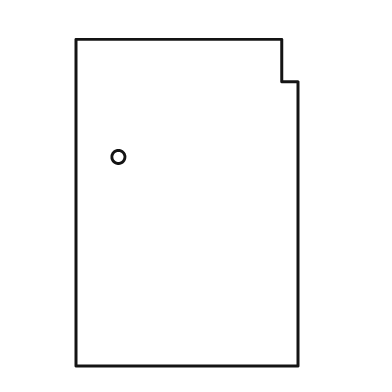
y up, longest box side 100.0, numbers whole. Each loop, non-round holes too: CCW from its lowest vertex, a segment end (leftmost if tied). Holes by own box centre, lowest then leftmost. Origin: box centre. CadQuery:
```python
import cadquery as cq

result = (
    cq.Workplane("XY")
    .moveTo(-34.0, -50.0)
    .lineTo(34.0, -50.0)
    .lineTo(34.0, 37.0)
    .lineTo(29.0, 37.0)
    .lineTo(29.0, 50.0)
    .lineTo(-34.0, 50.0)
    .close()
    .moveTo(-21.0, 14.0)
    .circle(2.0)
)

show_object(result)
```